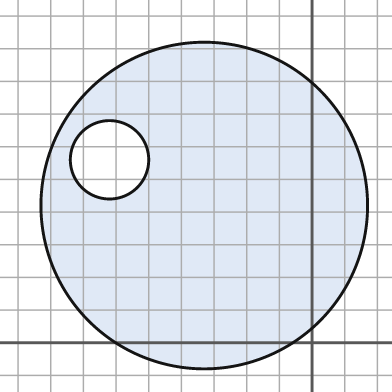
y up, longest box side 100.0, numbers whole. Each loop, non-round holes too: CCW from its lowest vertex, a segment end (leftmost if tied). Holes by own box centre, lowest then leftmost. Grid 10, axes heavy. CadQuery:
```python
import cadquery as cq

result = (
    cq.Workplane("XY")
    .moveTo(-33.0, 42.0)
    .circle(50.0)
    .moveTo(-62.0, 56.0)
    .circle(12.0)
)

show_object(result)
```